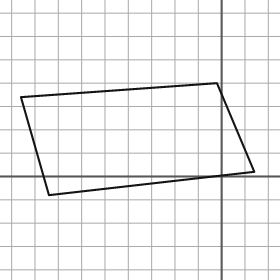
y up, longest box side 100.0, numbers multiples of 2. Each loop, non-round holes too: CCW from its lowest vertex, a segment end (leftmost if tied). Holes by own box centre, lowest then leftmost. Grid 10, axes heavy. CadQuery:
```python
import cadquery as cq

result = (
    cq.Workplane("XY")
    .moveTo(-74.0, -8.0)
    .lineTo(14.0, 2.0)
    .lineTo(-2.0, 40.0)
    .lineTo(-86.0, 34.0)
    .close()
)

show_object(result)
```